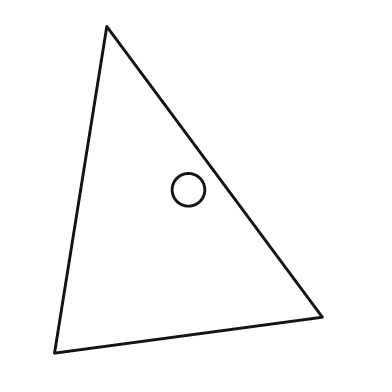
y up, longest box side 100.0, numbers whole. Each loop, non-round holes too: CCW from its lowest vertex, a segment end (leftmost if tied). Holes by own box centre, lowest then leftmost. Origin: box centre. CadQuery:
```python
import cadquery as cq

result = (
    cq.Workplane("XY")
    .moveTo(-41.0, -50.0)
    .lineTo(41.0, -39.0)
    .lineTo(-25.0, 50.0)
    .close()
    .moveTo(0.0, 0.0)
    .circle(5.0)
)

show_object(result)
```